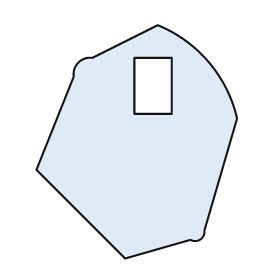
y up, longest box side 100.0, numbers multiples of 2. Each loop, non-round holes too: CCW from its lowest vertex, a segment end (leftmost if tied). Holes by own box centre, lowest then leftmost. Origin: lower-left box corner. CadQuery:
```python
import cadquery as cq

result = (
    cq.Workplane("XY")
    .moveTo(38.0, 0.0)
    .lineTo(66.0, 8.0)
    .threePointArc((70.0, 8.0), (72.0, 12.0))
    .lineTo(86.0, 60.0)
    .threePointArc((74.0, 84.0), (52.0, 100.0))
    .lineTo(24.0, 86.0)
    .threePointArc((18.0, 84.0), (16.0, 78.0))
    .lineTo(0.0, 38.0)
    .close()
    .moveTo(42.0, 62.0)
    .lineTo(58.0, 62.0)
    .lineTo(58.0, 86.0)
    .lineTo(42.0, 86.0)
    .close()
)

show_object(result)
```